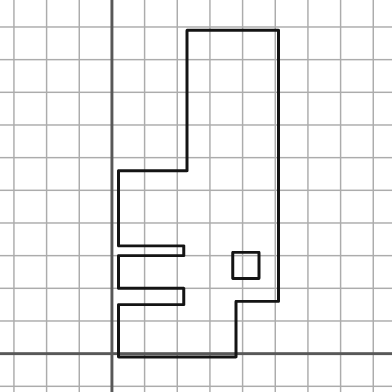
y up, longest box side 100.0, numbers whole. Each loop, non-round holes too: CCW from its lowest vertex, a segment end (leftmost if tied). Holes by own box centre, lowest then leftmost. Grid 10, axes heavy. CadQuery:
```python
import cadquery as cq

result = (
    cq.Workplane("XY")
    .moveTo(2.0, -1.0)
    .lineTo(38.0, -1.0)
    .lineTo(38.0, 16.0)
    .lineTo(51.0, 16.0)
    .lineTo(51.0, 99.0)
    .lineTo(23.0, 99.0)
    .lineTo(23.0, 56.0)
    .lineTo(2.0, 56.0)
    .lineTo(2.0, 33.0)
    .lineTo(22.0, 33.0)
    .lineTo(22.0, 30.0)
    .lineTo(2.0, 30.0)
    .lineTo(2.0, 20.0)
    .lineTo(22.0, 20.0)
    .lineTo(22.0, 15.0)
    .lineTo(2.0, 15.0)
    .close()
    .moveTo(37.0, 23.0)
    .lineTo(45.0, 23.0)
    .lineTo(45.0, 31.0)
    .lineTo(37.0, 31.0)
    .close()
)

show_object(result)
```